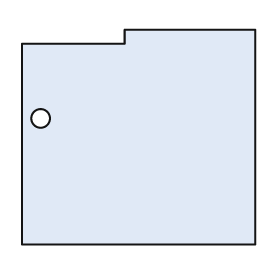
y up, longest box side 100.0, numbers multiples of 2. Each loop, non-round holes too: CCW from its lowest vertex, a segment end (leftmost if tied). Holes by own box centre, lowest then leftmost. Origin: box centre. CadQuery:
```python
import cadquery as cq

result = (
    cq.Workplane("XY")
    .moveTo(-50.0, -46.0)
    .lineTo(50.0, -46.0)
    .lineTo(50.0, 46.0)
    .lineTo(-6.0, 46.0)
    .lineTo(-6.0, 40.0)
    .lineTo(-50.0, 40.0)
    .close()
    .moveTo(-42.0, 8.0)
    .circle(4.0)
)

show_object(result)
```